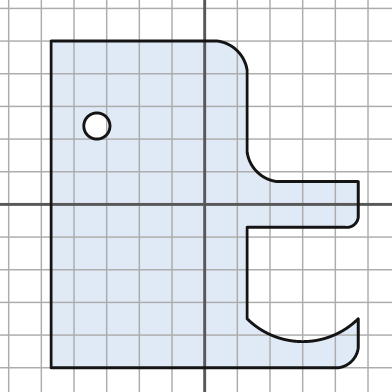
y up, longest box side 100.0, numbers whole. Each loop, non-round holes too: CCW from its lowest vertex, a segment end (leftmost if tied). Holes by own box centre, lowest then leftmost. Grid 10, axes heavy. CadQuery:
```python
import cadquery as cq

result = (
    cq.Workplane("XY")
    .moveTo(-47.0, -50.0)
    .lineTo(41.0, -50.0)
    .threePointArc((45.0, -48.0), (47.0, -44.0))
    .lineTo(47.0, -35.0)
    .threePointArc((30.0, -42.0), (13.0, -35.0))
    .lineTo(13.0, -7.0)
    .lineTo(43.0, -7.0)
    .threePointArc((46.0, -6.0), (47.0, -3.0))
    .lineTo(47.0, 7.0)
    .lineTo(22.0, 7.0)
    .threePointArc((16.0, 10.0), (13.0, 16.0))
    .lineTo(13.0, 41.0)
    .threePointArc((10.0, 47.0), (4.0, 50.0))
    .lineTo(-47.0, 50.0)
    .close()
    .moveTo(-33.0, 24.0)
    .circle(4.0)
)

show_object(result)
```